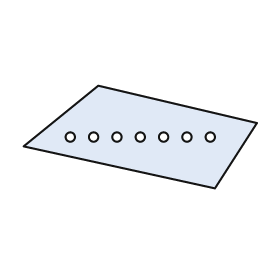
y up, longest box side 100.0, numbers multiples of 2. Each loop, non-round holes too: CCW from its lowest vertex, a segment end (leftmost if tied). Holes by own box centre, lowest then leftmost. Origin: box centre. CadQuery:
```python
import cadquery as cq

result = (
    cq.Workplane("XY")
    .moveTo(32.0, -22.0)
    .lineTo(50.0, 6.0)
    .lineTo(-18.0, 22.0)
    .lineTo(-50.0, -4.0)
    .close()
    .moveTo(-30.0, 0.0)
    .circle(2.0)
    .moveTo(-20.0, 0.0)
    .circle(2.0)
    .moveTo(-10.0, 0.0)
    .circle(2.0)
    .moveTo(0.0, 0.0)
    .circle(2.0)
    .moveTo(10.0, 0.0)
    .circle(2.0)
    .moveTo(20.0, 0.0)
    .circle(2.0)
    .moveTo(30.0, 0.0)
    .circle(2.0)
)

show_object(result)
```